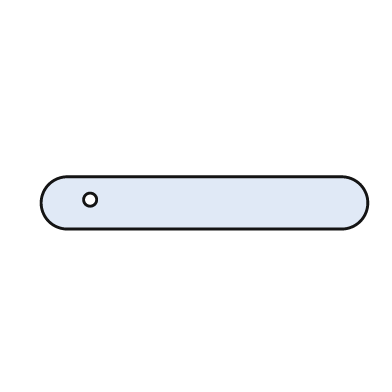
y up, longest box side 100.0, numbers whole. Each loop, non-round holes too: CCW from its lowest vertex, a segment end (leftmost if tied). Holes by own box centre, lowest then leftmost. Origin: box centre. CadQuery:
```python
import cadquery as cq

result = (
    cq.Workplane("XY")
    .moveTo(-42.0, -8.0)
    .lineTo(42.0, -8.0)
    .threePointArc((50.0, 0.0), (42.0, 8.0))
    .lineTo(-42.0, 8.0)
    .threePointArc((-50.0, 0.0), (-42.0, -8.0))
    .close()
    .moveTo(-35.0, 1.0)
    .circle(2.0)
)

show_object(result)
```